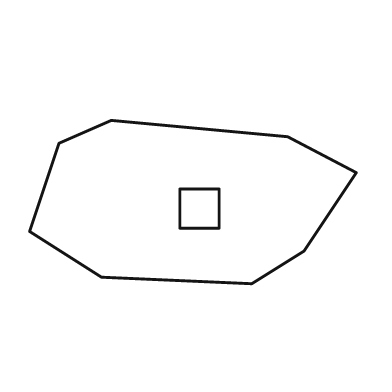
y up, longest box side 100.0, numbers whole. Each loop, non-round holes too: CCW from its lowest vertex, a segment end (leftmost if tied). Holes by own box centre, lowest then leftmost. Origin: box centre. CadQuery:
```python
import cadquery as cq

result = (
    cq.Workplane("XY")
    .moveTo(18.0, -25.0)
    .lineTo(34.0, -15.0)
    .lineTo(50.0, 9.0)
    .lineTo(29.0, 20.0)
    .lineTo(-25.0, 25.0)
    .lineTo(-41.0, 18.0)
    .lineTo(-50.0, -9.0)
    .lineTo(-28.0, -23.0)
    .close()
    .moveTo(-4.0, -8.0)
    .lineTo(8.0, -8.0)
    .lineTo(8.0, 4.0)
    .lineTo(-4.0, 4.0)
    .close()
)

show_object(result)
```